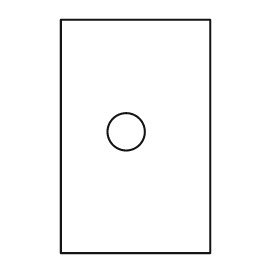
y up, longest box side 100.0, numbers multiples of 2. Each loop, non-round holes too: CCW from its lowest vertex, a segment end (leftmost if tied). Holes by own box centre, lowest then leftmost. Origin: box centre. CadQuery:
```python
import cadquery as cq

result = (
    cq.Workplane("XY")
    .moveTo(-32.0, -50.0)
    .lineTo(32.0, -50.0)
    .lineTo(32.0, 50.0)
    .lineTo(-32.0, 50.0)
    .close()
    .moveTo(-4.0, 2.0)
    .circle(8.0)
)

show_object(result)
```